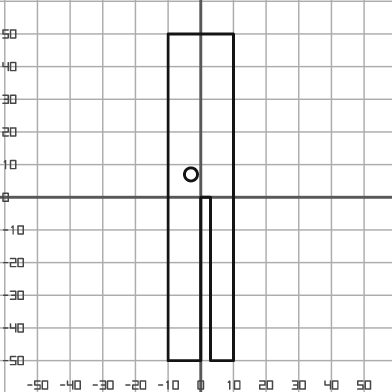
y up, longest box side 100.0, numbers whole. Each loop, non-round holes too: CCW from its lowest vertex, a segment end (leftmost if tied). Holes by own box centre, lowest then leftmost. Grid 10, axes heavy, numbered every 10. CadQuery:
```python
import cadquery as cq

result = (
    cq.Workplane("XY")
    .moveTo(-10.0, -50.0)
    .lineTo(0.0, -50.0)
    .lineTo(0.0, 0.0)
    .lineTo(3.0, 0.0)
    .lineTo(3.0, -50.0)
    .lineTo(10.0, -50.0)
    .lineTo(10.0, 50.0)
    .lineTo(-10.0, 50.0)
    .close()
    .moveTo(-3.0, 7.0)
    .circle(2.0)
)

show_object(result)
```